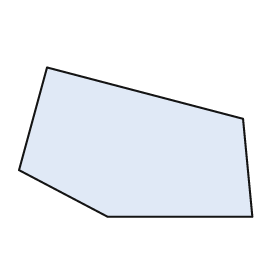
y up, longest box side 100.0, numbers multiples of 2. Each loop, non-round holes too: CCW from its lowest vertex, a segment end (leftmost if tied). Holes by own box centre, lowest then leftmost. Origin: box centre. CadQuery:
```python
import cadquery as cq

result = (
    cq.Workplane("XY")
    .moveTo(-12.0, -32.0)
    .lineTo(50.0, -32.0)
    .lineTo(46.0, 10.0)
    .lineTo(-38.0, 32.0)
    .lineTo(-50.0, -12.0)
    .close()
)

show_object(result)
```